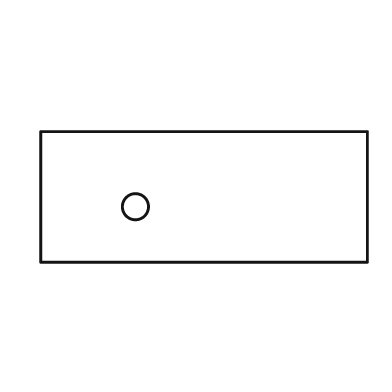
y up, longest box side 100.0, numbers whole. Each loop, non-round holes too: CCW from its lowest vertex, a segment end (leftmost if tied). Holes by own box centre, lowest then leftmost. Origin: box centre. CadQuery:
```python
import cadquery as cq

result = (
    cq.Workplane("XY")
    .moveTo(-50.0, -20.0)
    .lineTo(50.0, -20.0)
    .lineTo(50.0, 20.0)
    .lineTo(-50.0, 20.0)
    .close()
    .moveTo(-21.0, -3.0)
    .circle(4.0)
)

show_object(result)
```